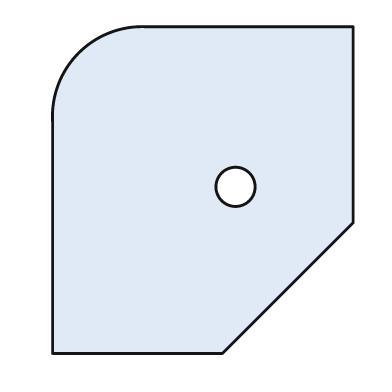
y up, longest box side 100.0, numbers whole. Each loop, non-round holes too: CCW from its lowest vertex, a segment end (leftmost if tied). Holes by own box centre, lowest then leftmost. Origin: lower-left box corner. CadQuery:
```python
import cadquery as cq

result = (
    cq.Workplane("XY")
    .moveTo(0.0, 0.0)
    .lineTo(52.0, 0.0)
    .lineTo(92.0, 40.0)
    .lineTo(92.0, 100.0)
    .lineTo(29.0, 100.0)
    .threePointArc((8.0, 92.0), (0.0, 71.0))
    .close()
    .moveTo(56.0, 51.0)
    .circle(6.0)
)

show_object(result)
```